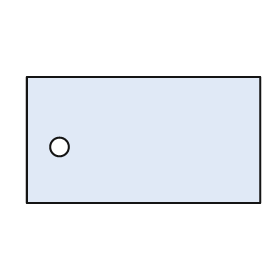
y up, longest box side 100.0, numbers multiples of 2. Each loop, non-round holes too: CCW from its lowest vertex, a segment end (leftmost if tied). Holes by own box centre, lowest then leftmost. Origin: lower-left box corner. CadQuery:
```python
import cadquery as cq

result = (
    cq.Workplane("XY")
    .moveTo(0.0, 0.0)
    .lineTo(100.0, 0.0)
    .lineTo(100.0, 54.0)
    .lineTo(0.0, 54.0)
    .close()
    .moveTo(14.0, 24.0)
    .circle(4.0)
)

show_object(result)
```